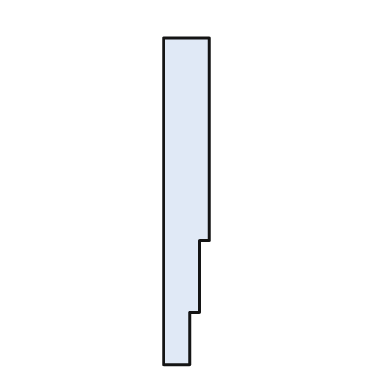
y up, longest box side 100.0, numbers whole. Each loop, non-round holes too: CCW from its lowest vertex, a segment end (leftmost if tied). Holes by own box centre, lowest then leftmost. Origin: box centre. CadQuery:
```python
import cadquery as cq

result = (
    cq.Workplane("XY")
    .moveTo(-7.0, -50.0)
    .lineTo(1.0, -50.0)
    .lineTo(1.0, -34.0)
    .lineTo(4.0, -34.0)
    .lineTo(4.0, -12.0)
    .lineTo(7.0, -12.0)
    .lineTo(7.0, 50.0)
    .lineTo(-7.0, 50.0)
    .close()
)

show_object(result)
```